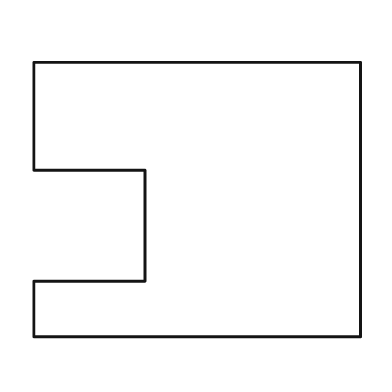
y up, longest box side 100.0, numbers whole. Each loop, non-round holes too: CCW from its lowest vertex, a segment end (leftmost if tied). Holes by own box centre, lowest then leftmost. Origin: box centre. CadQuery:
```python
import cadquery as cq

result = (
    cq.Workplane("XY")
    .moveTo(-50.0, -42.0)
    .lineTo(50.0, -42.0)
    .lineTo(50.0, 42.0)
    .lineTo(-50.0, 42.0)
    .lineTo(-50.0, 9.0)
    .lineTo(-16.0, 9.0)
    .lineTo(-16.0, -25.0)
    .lineTo(-50.0, -25.0)
    .close()
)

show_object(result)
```